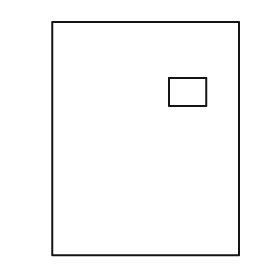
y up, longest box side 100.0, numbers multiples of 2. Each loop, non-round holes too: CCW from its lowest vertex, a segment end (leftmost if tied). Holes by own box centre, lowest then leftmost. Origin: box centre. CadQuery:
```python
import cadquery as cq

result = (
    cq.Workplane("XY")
    .moveTo(-40.0, -50.0)
    .lineTo(40.0, -50.0)
    .lineTo(40.0, 50.0)
    .lineTo(-40.0, 50.0)
    .close()
    .moveTo(10.0, 14.0)
    .lineTo(26.0, 14.0)
    .lineTo(26.0, 26.0)
    .lineTo(10.0, 26.0)
    .close()
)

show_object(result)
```